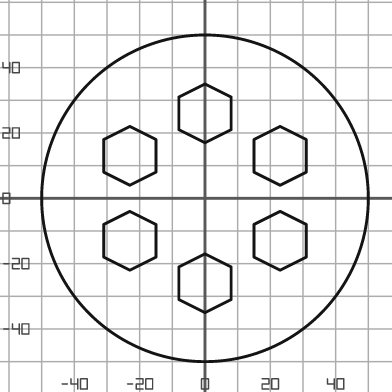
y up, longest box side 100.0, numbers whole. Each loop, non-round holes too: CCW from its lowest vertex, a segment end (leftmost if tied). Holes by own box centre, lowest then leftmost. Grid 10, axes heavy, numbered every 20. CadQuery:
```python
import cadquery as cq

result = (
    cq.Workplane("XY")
    .moveTo(0.0, 0.0)
    .circle(50.0)
    .moveTo(0.0, -35.0)
    .lineTo(8.0, -31.0)
    .lineTo(8.0, -21.0)
    .lineTo(0.0, -17.0)
    .lineTo(-8.0, -21.0)
    .lineTo(-8.0, -31.0)
    .close()
    .moveTo(-23.0, -22.0)
    .lineTo(-15.0, -18.0)
    .lineTo(-15.0, -8.0)
    .lineTo(-23.0, -4.0)
    .lineTo(-31.0, -8.0)
    .lineTo(-31.0, -18.0)
    .close()
    .moveTo(23.0, -22.0)
    .lineTo(31.0, -18.0)
    .lineTo(31.0, -8.0)
    .lineTo(23.0, -4.0)
    .lineTo(15.0, -8.0)
    .lineTo(15.0, -18.0)
    .close()
    .moveTo(-23.0, 4.0)
    .lineTo(-15.0, 8.0)
    .lineTo(-15.0, 18.0)
    .lineTo(-23.0, 22.0)
    .lineTo(-31.0, 18.0)
    .lineTo(-31.0, 8.0)
    .close()
    .moveTo(23.0, 4.0)
    .lineTo(31.0, 8.0)
    .lineTo(31.0, 18.0)
    .lineTo(23.0, 22.0)
    .lineTo(15.0, 18.0)
    .lineTo(15.0, 8.0)
    .close()
    .moveTo(0.0, 17.0)
    .lineTo(8.0, 21.0)
    .lineTo(8.0, 31.0)
    .lineTo(0.0, 35.0)
    .lineTo(-8.0, 31.0)
    .lineTo(-8.0, 21.0)
    .close()
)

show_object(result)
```